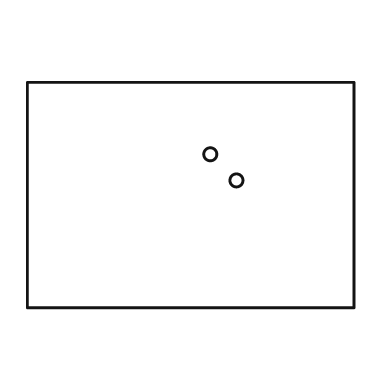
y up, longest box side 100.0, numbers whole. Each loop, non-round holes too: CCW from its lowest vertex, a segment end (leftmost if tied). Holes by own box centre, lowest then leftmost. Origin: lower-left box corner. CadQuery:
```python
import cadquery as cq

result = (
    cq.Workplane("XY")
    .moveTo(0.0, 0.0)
    .lineTo(100.0, 0.0)
    .lineTo(100.0, 69.0)
    .lineTo(0.0, 69.0)
    .close()
    .moveTo(64.0, 39.0)
    .circle(2.0)
    .moveTo(56.0, 47.0)
    .circle(2.0)
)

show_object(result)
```